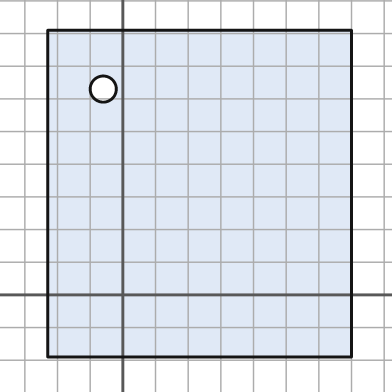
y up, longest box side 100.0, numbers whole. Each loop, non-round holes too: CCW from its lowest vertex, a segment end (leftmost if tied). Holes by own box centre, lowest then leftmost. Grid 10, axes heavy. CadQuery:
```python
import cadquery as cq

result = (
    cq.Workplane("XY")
    .moveTo(-23.0, -19.0)
    .lineTo(70.0, -19.0)
    .lineTo(70.0, 81.0)
    .lineTo(-23.0, 81.0)
    .close()
    .moveTo(-6.0, 63.0)
    .circle(4.0)
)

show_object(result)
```